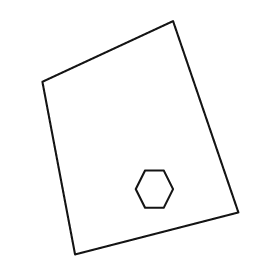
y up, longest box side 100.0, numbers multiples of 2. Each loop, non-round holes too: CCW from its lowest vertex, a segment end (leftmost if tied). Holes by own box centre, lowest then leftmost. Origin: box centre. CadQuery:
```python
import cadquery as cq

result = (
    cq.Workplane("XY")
    .moveTo(-28.0, -50.0)
    .lineTo(42.0, -32.0)
    .lineTo(14.0, 50.0)
    .lineTo(-42.0, 24.0)
    .close()
    .moveTo(2.0, -30.0)
    .lineTo(10.0, -30.0)
    .lineTo(14.0, -22.0)
    .lineTo(10.0, -14.0)
    .lineTo(2.0, -14.0)
    .lineTo(-2.0, -22.0)
    .close()
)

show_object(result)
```